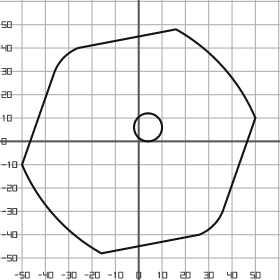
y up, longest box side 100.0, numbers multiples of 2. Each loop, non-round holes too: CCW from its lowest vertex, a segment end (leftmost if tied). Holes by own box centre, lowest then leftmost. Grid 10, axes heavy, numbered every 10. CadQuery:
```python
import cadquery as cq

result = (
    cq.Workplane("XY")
    .moveTo(-16.0, -48.0)
    .lineTo(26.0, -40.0)
    .threePointArc((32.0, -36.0), (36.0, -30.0))
    .lineTo(50.0, 10.0)
    .threePointArc((36.0, 32.0), (16.0, 48.0))
    .lineTo(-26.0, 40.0)
    .threePointArc((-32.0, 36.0), (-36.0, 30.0))
    .lineTo(-50.0, -10.0)
    .threePointArc((-36.0, -32.0), (-16.0, -48.0))
    .close()
    .moveTo(4.0, 6.0)
    .circle(6.0)
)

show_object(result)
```